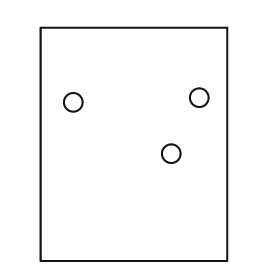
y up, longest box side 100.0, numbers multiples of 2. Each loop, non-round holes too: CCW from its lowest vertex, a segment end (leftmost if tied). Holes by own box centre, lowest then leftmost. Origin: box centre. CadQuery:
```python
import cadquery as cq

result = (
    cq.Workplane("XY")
    .moveTo(-40.0, -50.0)
    .lineTo(40.0, -50.0)
    .lineTo(40.0, 50.0)
    .lineTo(-40.0, 50.0)
    .close()
    .moveTo(16.0, -4.0)
    .circle(4.0)
    .moveTo(-26.0, 18.0)
    .circle(4.0)
    .moveTo(28.0, 20.0)
    .circle(4.0)
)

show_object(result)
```